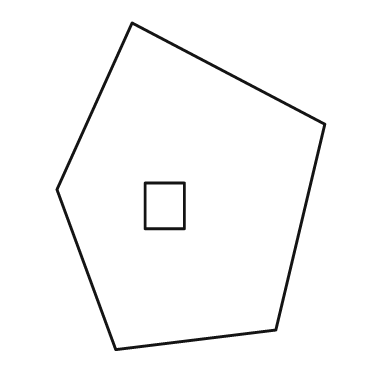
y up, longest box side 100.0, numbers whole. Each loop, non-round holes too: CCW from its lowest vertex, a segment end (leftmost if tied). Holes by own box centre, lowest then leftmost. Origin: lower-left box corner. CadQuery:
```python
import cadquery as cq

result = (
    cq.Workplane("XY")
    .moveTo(18.0, 0.0)
    .lineTo(67.0, 6.0)
    .lineTo(82.0, 69.0)
    .lineTo(23.0, 100.0)
    .lineTo(0.0, 49.0)
    .close()
    .moveTo(27.0, 37.0)
    .lineTo(39.0, 37.0)
    .lineTo(39.0, 51.0)
    .lineTo(27.0, 51.0)
    .close()
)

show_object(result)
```